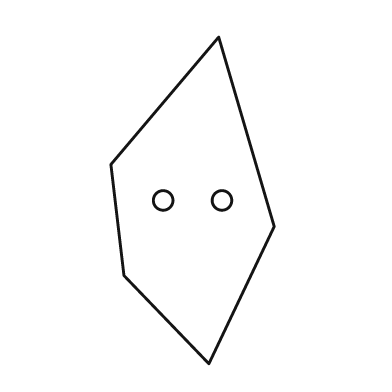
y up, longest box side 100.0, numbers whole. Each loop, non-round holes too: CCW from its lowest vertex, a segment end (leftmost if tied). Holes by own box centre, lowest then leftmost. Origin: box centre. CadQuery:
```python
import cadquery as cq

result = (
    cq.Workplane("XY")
    .moveTo(5.0, -50.0)
    .lineTo(25.0, -8.0)
    .lineTo(8.0, 50.0)
    .lineTo(-25.0, 11.0)
    .lineTo(-21.0, -23.0)
    .close()
    .moveTo(-9.0, 0.0)
    .circle(3.0)
    .moveTo(9.0, 0.0)
    .circle(3.0)
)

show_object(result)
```